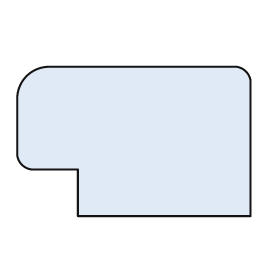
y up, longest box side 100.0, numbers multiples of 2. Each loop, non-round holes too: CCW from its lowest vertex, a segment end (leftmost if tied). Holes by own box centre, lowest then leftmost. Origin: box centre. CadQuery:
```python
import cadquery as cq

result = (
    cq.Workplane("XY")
    .moveTo(-24.0, -32.0)
    .lineTo(50.0, -32.0)
    .lineTo(50.0, 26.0)
    .threePointArc((48.0, 30.0), (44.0, 32.0))
    .lineTo(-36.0, 32.0)
    .threePointArc((-46.0, 28.0), (-50.0, 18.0))
    .lineTo(-50.0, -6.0)
    .threePointArc((-48.0, -10.0), (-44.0, -12.0))
    .lineTo(-24.0, -12.0)
    .close()
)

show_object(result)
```